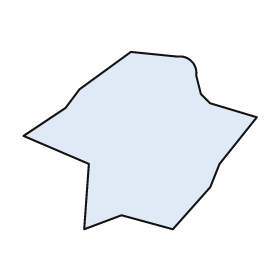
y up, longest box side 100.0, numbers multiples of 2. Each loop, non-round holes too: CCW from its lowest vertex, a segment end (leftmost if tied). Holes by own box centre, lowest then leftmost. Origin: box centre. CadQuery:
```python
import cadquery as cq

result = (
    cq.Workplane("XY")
    .moveTo(-24.0, -38.0)
    .lineTo(-8.0, -32.0)
    .lineTo(14.0, -38.0)
    .lineTo(30.0, -20.0)
    .lineTo(34.0, -10.0)
    .lineTo(50.0, 10.0)
    .lineTo(30.0, 16.0)
    .lineTo(26.0, 20.0)
    .lineTo(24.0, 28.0)
    .threePointArc((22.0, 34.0), (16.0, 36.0))
    .lineTo(-4.0, 38.0)
    .lineTo(-26.0, 22.0)
    .lineTo(-32.0, 14.0)
    .lineTo(-50.0, 2.0)
    .lineTo(-22.0, -10.0)
    .close()
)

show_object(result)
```